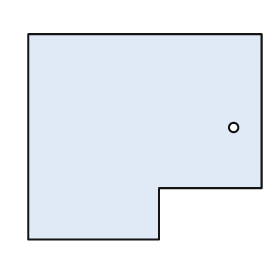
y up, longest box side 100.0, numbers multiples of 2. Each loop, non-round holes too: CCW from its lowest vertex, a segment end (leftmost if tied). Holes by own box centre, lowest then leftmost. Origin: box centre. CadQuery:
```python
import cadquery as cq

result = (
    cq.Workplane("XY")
    .moveTo(-50.0, -44.0)
    .lineTo(6.0, -44.0)
    .lineTo(6.0, -22.0)
    .lineTo(50.0, -22.0)
    .lineTo(50.0, 44.0)
    .lineTo(-50.0, 44.0)
    .close()
    .moveTo(38.0, 4.0)
    .circle(2.0)
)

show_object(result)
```